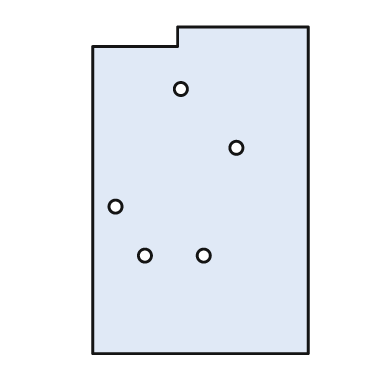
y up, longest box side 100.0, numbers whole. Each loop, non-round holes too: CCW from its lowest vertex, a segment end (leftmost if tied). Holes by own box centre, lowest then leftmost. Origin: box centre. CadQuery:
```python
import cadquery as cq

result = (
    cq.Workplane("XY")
    .moveTo(-33.0, -50.0)
    .lineTo(33.0, -50.0)
    .lineTo(33.0, 50.0)
    .lineTo(-7.0, 50.0)
    .lineTo(-7.0, 44.0)
    .lineTo(-33.0, 44.0)
    .close()
    .moveTo(-17.0, -20.0)
    .circle(2.0)
    .moveTo(1.0, -20.0)
    .circle(2.0)
    .moveTo(-26.0, -5.0)
    .circle(2.0)
    .moveTo(11.0, 13.0)
    .circle(2.0)
    .moveTo(-6.0, 31.0)
    .circle(2.0)
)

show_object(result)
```